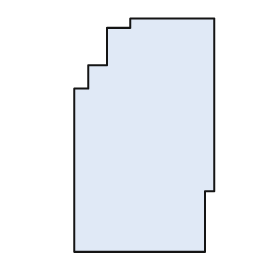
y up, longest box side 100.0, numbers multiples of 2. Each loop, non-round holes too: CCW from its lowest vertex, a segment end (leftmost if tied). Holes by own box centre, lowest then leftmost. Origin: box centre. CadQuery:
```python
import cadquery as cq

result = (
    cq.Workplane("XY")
    .moveTo(-30.0, -50.0)
    .lineTo(26.0, -50.0)
    .lineTo(26.0, -24.0)
    .lineTo(30.0, -24.0)
    .lineTo(30.0, 50.0)
    .lineTo(-6.0, 50.0)
    .lineTo(-6.0, 46.0)
    .lineTo(-16.0, 46.0)
    .lineTo(-16.0, 30.0)
    .lineTo(-24.0, 30.0)
    .lineTo(-24.0, 20.0)
    .lineTo(-30.0, 20.0)
    .close()
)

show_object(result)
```